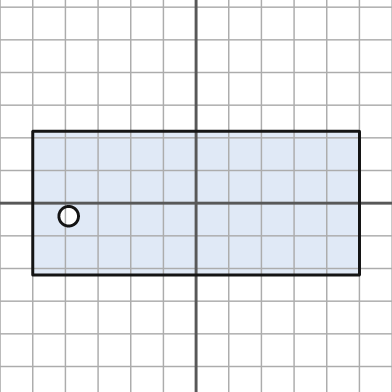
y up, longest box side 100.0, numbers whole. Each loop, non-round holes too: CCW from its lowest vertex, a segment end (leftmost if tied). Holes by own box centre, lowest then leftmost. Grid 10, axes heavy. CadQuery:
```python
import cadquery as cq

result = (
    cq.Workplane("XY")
    .moveTo(-50.0, -22.0)
    .lineTo(50.0, -22.0)
    .lineTo(50.0, 22.0)
    .lineTo(-50.0, 22.0)
    .close()
    .moveTo(-39.0, -4.0)
    .circle(3.0)
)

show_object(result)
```